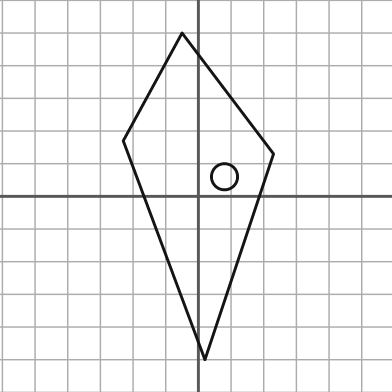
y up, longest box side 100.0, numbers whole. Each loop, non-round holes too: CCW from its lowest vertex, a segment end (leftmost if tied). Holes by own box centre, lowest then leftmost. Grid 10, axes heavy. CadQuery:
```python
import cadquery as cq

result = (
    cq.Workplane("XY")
    .moveTo(2.0, -50.0)
    .lineTo(23.0, 13.0)
    .lineTo(-5.0, 50.0)
    .lineTo(-23.0, 17.0)
    .close()
    .moveTo(8.0, 6.0)
    .circle(4.0)
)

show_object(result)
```